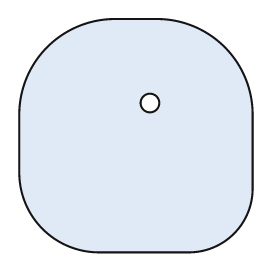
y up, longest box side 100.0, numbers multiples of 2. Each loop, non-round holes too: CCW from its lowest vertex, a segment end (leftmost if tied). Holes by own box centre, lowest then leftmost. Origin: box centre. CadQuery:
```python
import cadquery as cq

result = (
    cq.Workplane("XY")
    .moveTo(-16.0, -50.0)
    .lineTo(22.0, -50.0)
    .threePointArc((42.0, -42.0), (50.0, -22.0))
    .lineTo(50.0, 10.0)
    .threePointArc((38.0, 38.0), (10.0, 50.0))
    .lineTo(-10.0, 50.0)
    .threePointArc((-38.0, 38.0), (-50.0, 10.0))
    .lineTo(-50.0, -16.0)
    .threePointArc((-40.0, -40.0), (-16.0, -50.0))
    .close()
    .moveTo(6.0, 14.0)
    .circle(4.0)
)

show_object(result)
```